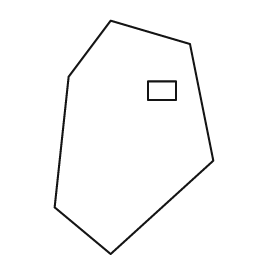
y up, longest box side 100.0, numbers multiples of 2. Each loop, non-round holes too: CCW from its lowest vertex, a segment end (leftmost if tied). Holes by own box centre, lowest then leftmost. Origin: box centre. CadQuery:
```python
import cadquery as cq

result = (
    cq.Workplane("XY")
    .moveTo(-10.0, -50.0)
    .lineTo(34.0, -10.0)
    .lineTo(24.0, 40.0)
    .lineTo(-10.0, 50.0)
    .lineTo(-28.0, 26.0)
    .lineTo(-34.0, -30.0)
    .close()
    .moveTo(6.0, 16.0)
    .lineTo(18.0, 16.0)
    .lineTo(18.0, 24.0)
    .lineTo(6.0, 24.0)
    .close()
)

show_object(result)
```